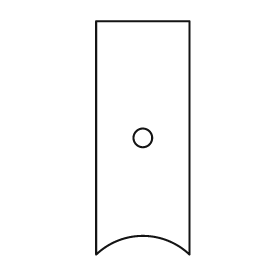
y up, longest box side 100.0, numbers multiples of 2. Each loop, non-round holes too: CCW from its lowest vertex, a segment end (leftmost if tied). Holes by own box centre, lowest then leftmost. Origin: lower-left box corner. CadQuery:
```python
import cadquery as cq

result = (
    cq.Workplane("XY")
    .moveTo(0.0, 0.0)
    .threePointArc((20.0, 8.0), (40.0, 0.0))
    .lineTo(40.0, 100.0)
    .lineTo(0.0, 100.0)
    .close()
    .moveTo(20.0, 50.0)
    .circle(4.0)
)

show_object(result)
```